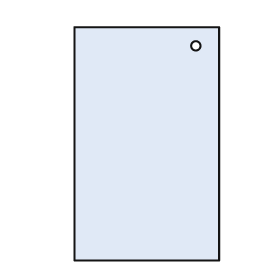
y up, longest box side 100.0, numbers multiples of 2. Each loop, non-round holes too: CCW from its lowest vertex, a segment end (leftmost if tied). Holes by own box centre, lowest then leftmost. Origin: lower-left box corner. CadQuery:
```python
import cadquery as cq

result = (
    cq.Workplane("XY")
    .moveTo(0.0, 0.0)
    .lineTo(62.0, 0.0)
    .lineTo(62.0, 100.0)
    .lineTo(0.0, 100.0)
    .close()
    .moveTo(52.0, 92.0)
    .circle(2.0)
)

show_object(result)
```